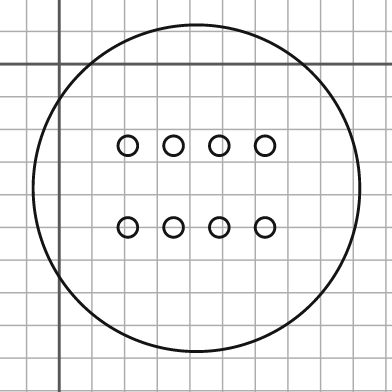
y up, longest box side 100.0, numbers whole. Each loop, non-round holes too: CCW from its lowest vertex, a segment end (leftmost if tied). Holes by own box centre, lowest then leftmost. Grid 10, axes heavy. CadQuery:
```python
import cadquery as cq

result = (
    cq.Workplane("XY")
    .moveTo(42.0, -38.0)
    .circle(50.0)
    .moveTo(21.0, -50.0)
    .circle(3.0)
    .moveTo(35.0, -50.0)
    .circle(3.0)
    .moveTo(49.0, -50.0)
    .circle(3.0)
    .moveTo(63.0, -50.0)
    .circle(3.0)
    .moveTo(21.0, -25.0)
    .circle(3.0)
    .moveTo(35.0, -25.0)
    .circle(3.0)
    .moveTo(49.0, -25.0)
    .circle(3.0)
    .moveTo(63.0, -25.0)
    .circle(3.0)
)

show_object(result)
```